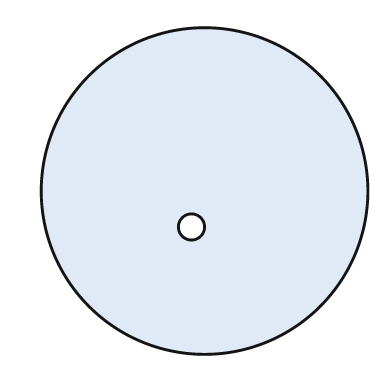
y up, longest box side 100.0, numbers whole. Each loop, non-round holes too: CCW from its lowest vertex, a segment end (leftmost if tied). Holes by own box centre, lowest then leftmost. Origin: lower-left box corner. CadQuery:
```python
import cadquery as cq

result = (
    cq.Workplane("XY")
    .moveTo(50.0, 50.0)
    .circle(50.0)
    .moveTo(46.0, 39.0)
    .circle(4.0)
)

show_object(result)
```